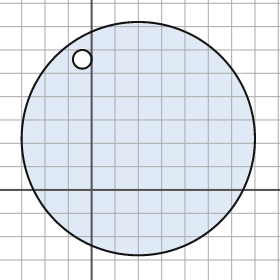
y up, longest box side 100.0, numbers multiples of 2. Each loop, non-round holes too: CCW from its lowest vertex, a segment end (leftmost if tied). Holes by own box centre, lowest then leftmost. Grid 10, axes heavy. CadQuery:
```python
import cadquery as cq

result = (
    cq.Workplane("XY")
    .moveTo(20.0, 22.0)
    .circle(50.0)
    .moveTo(-4.0, 56.0)
    .circle(4.0)
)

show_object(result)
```